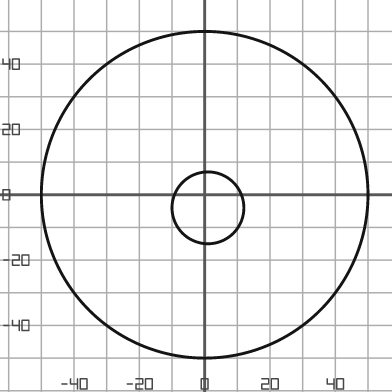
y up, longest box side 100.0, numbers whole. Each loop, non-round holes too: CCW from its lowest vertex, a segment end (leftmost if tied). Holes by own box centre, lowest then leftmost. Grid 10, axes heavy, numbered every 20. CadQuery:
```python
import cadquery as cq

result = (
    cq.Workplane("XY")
    .moveTo(0.0, 0.0)
    .circle(50.0)
    .moveTo(1.0, -4.0)
    .circle(11.0)
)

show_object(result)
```